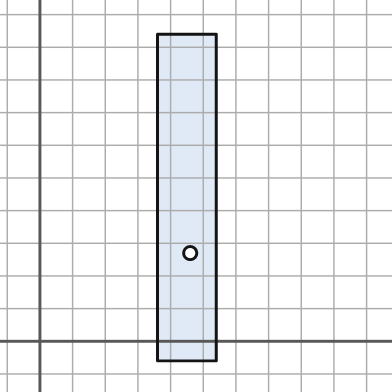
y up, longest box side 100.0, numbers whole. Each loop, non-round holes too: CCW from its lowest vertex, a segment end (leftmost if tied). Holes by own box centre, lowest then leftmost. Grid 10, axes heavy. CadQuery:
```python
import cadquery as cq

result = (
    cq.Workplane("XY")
    .moveTo(36.0, -6.0)
    .lineTo(54.0, -6.0)
    .lineTo(54.0, 94.0)
    .lineTo(36.0, 94.0)
    .close()
    .moveTo(46.0, 27.0)
    .circle(2.0)
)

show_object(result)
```